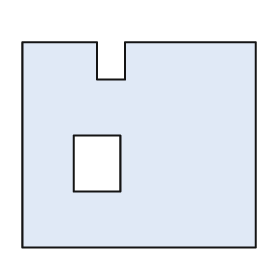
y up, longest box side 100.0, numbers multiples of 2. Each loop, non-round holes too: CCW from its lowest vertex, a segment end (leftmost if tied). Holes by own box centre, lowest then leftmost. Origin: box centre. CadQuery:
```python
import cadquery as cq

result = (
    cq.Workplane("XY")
    .moveTo(-50.0, -44.0)
    .lineTo(50.0, -44.0)
    .lineTo(50.0, 44.0)
    .lineTo(-6.0, 44.0)
    .lineTo(-6.0, 28.0)
    .lineTo(-18.0, 28.0)
    .lineTo(-18.0, 44.0)
    .lineTo(-50.0, 44.0)
    .close()
    .moveTo(-28.0, -20.0)
    .lineTo(-8.0, -20.0)
    .lineTo(-8.0, 4.0)
    .lineTo(-28.0, 4.0)
    .close()
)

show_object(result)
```